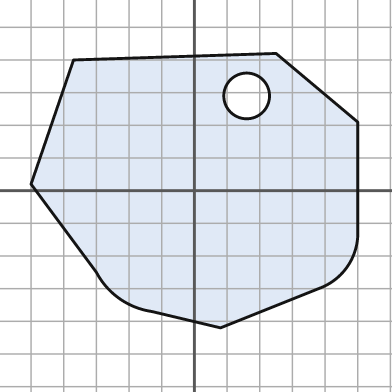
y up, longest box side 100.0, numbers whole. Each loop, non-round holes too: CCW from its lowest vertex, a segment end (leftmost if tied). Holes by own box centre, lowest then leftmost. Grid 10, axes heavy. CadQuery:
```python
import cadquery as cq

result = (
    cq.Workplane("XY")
    .moveTo(8.0, -42.0)
    .lineTo(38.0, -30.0)
    .threePointArc((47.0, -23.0), (50.0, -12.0))
    .lineTo(50.0, 21.0)
    .lineTo(25.0, 42.0)
    .lineTo(-37.0, 40.0)
    .lineTo(-50.0, 2.0)
    .lineTo(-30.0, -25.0)
    .threePointArc((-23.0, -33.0), (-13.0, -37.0))
    .close()
    .moveTo(16.0, 29.0)
    .circle(7.0)
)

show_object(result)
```